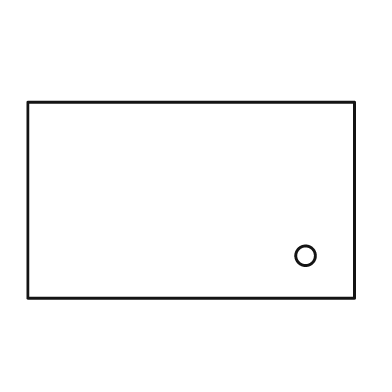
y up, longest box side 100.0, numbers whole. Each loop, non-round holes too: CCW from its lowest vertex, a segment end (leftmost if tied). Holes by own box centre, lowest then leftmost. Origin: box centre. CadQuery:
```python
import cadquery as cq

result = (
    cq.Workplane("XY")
    .moveTo(-50.0, -30.0)
    .lineTo(50.0, -30.0)
    .lineTo(50.0, 30.0)
    .lineTo(-50.0, 30.0)
    .close()
    .moveTo(35.0, -17.0)
    .circle(3.0)
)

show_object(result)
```